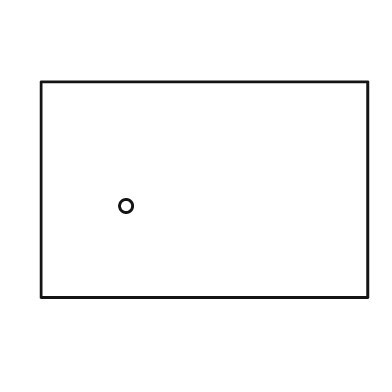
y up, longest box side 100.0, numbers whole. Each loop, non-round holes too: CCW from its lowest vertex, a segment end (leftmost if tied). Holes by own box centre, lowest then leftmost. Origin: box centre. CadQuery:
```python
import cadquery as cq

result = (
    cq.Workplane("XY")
    .moveTo(-50.0, -33.0)
    .lineTo(50.0, -33.0)
    .lineTo(50.0, 33.0)
    .lineTo(-50.0, 33.0)
    .close()
    .moveTo(-24.0, -5.0)
    .circle(2.0)
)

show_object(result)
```